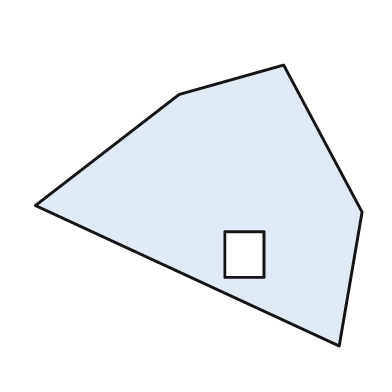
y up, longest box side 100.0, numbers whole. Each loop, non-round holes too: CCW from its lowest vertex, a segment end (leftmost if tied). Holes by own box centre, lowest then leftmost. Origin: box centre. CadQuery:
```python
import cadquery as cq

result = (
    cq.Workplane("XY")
    .moveTo(43.0, -43.0)
    .lineTo(50.0, -2.0)
    .lineTo(26.0, 43.0)
    .lineTo(-6.0, 34.0)
    .lineTo(-50.0, 0.0)
    .close()
    .moveTo(8.0, -22.0)
    .lineTo(20.0, -22.0)
    .lineTo(20.0, -8.0)
    .lineTo(8.0, -8.0)
    .close()
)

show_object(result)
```